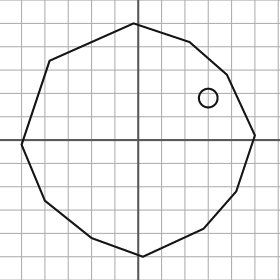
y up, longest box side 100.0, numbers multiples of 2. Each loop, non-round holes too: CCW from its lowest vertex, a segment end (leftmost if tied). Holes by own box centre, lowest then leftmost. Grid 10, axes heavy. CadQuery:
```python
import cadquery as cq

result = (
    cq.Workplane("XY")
    .moveTo(2.0, -50.0)
    .lineTo(28.0, -38.0)
    .lineTo(42.0, -22.0)
    .lineTo(50.0, 2.0)
    .lineTo(38.0, 28.0)
    .lineTo(22.0, 42.0)
    .lineTo(-2.0, 50.0)
    .lineTo(-38.0, 34.0)
    .lineTo(-50.0, -2.0)
    .lineTo(-40.0, -26.0)
    .lineTo(-20.0, -42.0)
    .close()
    .moveTo(30.0, 18.0)
    .circle(4.0)
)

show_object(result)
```